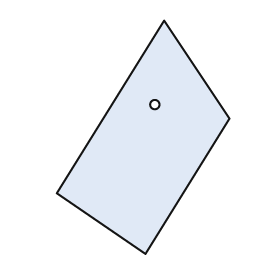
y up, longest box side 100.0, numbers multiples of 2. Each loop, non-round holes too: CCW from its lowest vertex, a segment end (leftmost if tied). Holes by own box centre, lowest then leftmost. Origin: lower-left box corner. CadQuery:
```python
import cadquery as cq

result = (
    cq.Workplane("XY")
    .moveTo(38.0, 0.0)
    .lineTo(74.0, 58.0)
    .lineTo(46.0, 100.0)
    .lineTo(0.0, 26.0)
    .close()
    .moveTo(42.0, 64.0)
    .circle(2.0)
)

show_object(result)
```